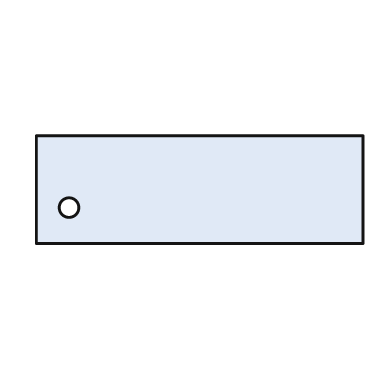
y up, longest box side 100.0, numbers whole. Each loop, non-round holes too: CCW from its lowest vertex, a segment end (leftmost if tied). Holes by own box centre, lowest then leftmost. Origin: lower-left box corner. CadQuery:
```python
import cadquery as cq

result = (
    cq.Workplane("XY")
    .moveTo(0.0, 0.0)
    .lineTo(100.0, 0.0)
    .lineTo(100.0, 33.0)
    .lineTo(0.0, 33.0)
    .close()
    .moveTo(10.0, 11.0)
    .circle(3.0)
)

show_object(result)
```